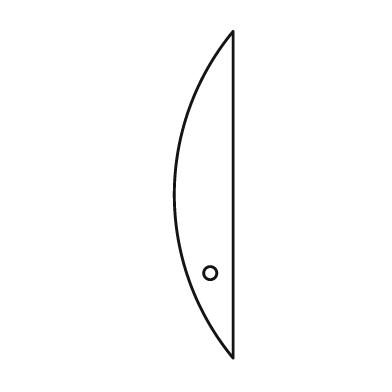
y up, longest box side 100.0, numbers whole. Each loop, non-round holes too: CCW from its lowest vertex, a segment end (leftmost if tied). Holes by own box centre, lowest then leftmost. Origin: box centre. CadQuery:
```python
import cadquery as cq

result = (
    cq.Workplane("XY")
    .moveTo(9.0, -50.0)
    .lineTo(9.0, 50.0)
    .threePointArc((-9.0, 0.0), (9.0, -50.0))
    .close()
    .moveTo(2.0, -24.0)
    .circle(2.0)
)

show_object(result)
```